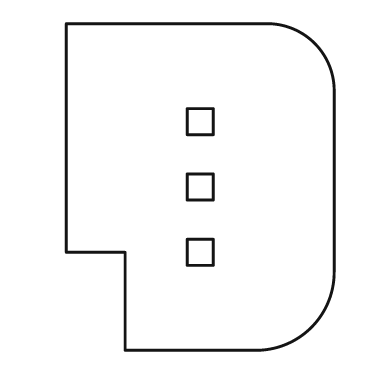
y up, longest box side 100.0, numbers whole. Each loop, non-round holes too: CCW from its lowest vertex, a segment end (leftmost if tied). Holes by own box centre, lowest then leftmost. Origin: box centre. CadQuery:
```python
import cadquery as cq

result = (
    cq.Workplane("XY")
    .moveTo(-23.0, -50.0)
    .lineTo(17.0, -50.0)
    .threePointArc((34.0, -43.0), (41.0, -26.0))
    .lineTo(41.0, 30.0)
    .threePointArc((35.0, 44.0), (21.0, 50.0))
    .lineTo(-41.0, 50.0)
    .lineTo(-41.0, -20.0)
    .lineTo(-23.0, -20.0)
    .close()
    .moveTo(-4.0, -24.0)
    .lineTo(4.0, -24.0)
    .lineTo(4.0, -16.0)
    .lineTo(-4.0, -16.0)
    .close()
    .moveTo(-4.0, -4.0)
    .lineTo(4.0, -4.0)
    .lineTo(4.0, 4.0)
    .lineTo(-4.0, 4.0)
    .close()
    .moveTo(-4.0, 16.0)
    .lineTo(4.0, 16.0)
    .lineTo(4.0, 24.0)
    .lineTo(-4.0, 24.0)
    .close()
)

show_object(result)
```